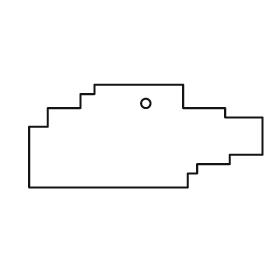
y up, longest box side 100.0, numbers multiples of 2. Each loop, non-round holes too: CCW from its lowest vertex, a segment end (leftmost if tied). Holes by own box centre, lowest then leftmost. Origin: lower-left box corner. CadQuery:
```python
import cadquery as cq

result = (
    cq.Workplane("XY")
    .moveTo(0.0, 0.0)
    .lineTo(68.0, 0.0)
    .lineTo(68.0, 6.0)
    .lineTo(72.0, 6.0)
    .lineTo(72.0, 10.0)
    .lineTo(86.0, 10.0)
    .lineTo(86.0, 14.0)
    .lineTo(100.0, 14.0)
    .lineTo(100.0, 30.0)
    .lineTo(84.0, 30.0)
    .lineTo(84.0, 34.0)
    .lineTo(66.0, 34.0)
    .lineTo(66.0, 44.0)
    .lineTo(28.0, 44.0)
    .lineTo(28.0, 40.0)
    .lineTo(22.0, 40.0)
    .lineTo(22.0, 34.0)
    .lineTo(8.0, 34.0)
    .lineTo(8.0, 26.0)
    .lineTo(0.0, 26.0)
    .close()
    .moveTo(50.0, 36.0)
    .circle(2.0)
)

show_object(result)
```